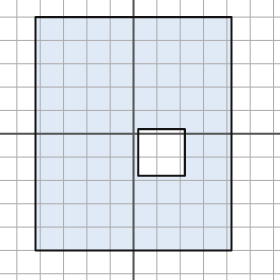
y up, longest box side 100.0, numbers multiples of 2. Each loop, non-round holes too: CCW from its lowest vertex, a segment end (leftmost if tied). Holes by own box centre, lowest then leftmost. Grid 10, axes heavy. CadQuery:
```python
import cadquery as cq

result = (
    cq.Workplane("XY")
    .moveTo(-42.0, -50.0)
    .lineTo(42.0, -50.0)
    .lineTo(42.0, 50.0)
    .lineTo(-42.0, 50.0)
    .close()
    .moveTo(2.0, -18.0)
    .lineTo(22.0, -18.0)
    .lineTo(22.0, 2.0)
    .lineTo(2.0, 2.0)
    .close()
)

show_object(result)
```